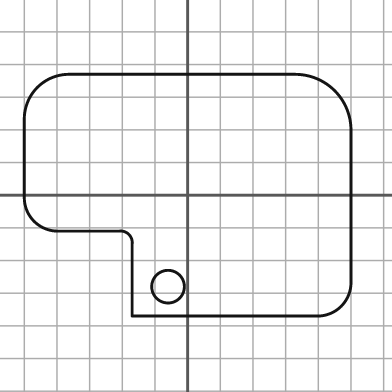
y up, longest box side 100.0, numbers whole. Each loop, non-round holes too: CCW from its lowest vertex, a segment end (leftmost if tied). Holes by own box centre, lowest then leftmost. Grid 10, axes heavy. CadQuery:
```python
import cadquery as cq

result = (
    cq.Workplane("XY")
    .moveTo(-17.0, -37.0)
    .lineTo(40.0, -37.0)
    .threePointArc((47.0, -34.0), (50.0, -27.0))
    .lineTo(50.0, 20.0)
    .threePointArc((45.0, 32.0), (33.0, 37.0))
    .lineTo(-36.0, 37.0)
    .threePointArc((-46.0, 33.0), (-50.0, 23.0))
    .lineTo(-50.0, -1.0)
    .threePointArc((-47.0, -8.0), (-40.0, -11.0))
    .lineTo(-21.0, -11.0)
    .threePointArc((-18.0, -12.0), (-17.0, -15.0))
    .close()
    .moveTo(-6.0, -28.0)
    .circle(5.0)
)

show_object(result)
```